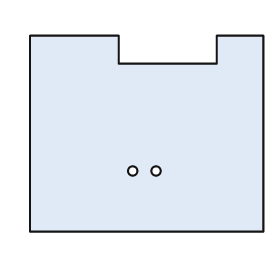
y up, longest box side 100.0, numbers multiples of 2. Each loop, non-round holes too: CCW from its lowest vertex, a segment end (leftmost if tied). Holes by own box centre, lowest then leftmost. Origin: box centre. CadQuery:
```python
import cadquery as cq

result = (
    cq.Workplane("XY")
    .moveTo(-50.0, -42.0)
    .lineTo(50.0, -42.0)
    .lineTo(50.0, 42.0)
    .lineTo(30.0, 42.0)
    .lineTo(30.0, 30.0)
    .lineTo(-12.0, 30.0)
    .lineTo(-12.0, 42.0)
    .lineTo(-50.0, 42.0)
    .close()
    .moveTo(-6.0, -16.0)
    .circle(2.0)
    .moveTo(4.0, -16.0)
    .circle(2.0)
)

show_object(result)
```